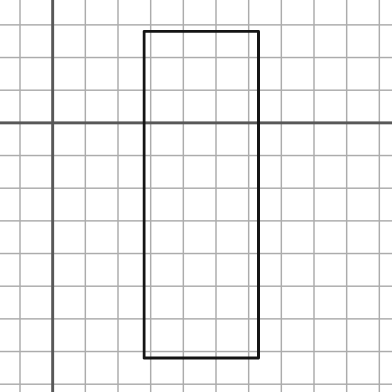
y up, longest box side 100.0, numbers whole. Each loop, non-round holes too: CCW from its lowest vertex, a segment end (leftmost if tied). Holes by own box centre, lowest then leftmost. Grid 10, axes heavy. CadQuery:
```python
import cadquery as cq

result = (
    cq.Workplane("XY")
    .moveTo(28.0, -72.0)
    .lineTo(63.0, -72.0)
    .lineTo(63.0, 28.0)
    .lineTo(28.0, 28.0)
    .close()
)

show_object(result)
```